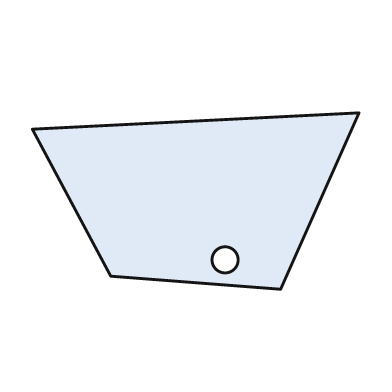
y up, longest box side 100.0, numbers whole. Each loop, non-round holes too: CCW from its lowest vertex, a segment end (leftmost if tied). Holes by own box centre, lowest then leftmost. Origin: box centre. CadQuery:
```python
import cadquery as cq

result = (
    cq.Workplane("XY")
    .moveTo(26.0, -27.0)
    .lineTo(50.0, 27.0)
    .lineTo(-50.0, 22.0)
    .lineTo(-26.0, -23.0)
    .close()
    .moveTo(9.0, -18.0)
    .circle(4.0)
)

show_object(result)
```